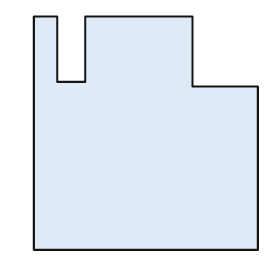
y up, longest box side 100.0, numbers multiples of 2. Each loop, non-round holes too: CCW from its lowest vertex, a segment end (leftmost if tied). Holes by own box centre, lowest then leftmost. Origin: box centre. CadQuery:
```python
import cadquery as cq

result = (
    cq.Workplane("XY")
    .moveTo(-48.0, -50.0)
    .lineTo(48.0, -50.0)
    .lineTo(48.0, 20.0)
    .lineTo(20.0, 20.0)
    .lineTo(20.0, 50.0)
    .lineTo(-26.0, 50.0)
    .lineTo(-26.0, 22.0)
    .lineTo(-38.0, 22.0)
    .lineTo(-38.0, 50.0)
    .lineTo(-48.0, 50.0)
    .close()
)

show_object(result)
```